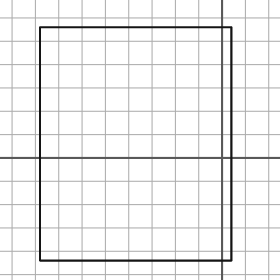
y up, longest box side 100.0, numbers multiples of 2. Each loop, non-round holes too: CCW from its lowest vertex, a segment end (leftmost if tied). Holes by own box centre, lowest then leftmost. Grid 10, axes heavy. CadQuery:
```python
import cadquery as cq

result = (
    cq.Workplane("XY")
    .moveTo(-78.0, -44.0)
    .lineTo(4.0, -44.0)
    .lineTo(4.0, 56.0)
    .lineTo(-78.0, 56.0)
    .close()
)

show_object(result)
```